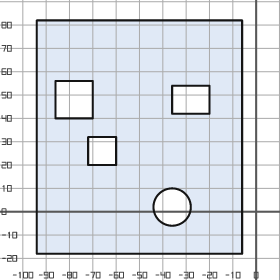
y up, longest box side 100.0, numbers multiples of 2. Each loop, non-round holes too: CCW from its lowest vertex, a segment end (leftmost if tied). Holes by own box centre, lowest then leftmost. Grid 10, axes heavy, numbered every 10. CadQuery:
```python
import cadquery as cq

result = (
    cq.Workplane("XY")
    .moveTo(-94.0, -18.0)
    .lineTo(-6.0, -18.0)
    .lineTo(-6.0, 82.0)
    .lineTo(-94.0, 82.0)
    .close()
    .moveTo(-36.0, 2.0)
    .circle(8.0)
    .moveTo(-72.0, 20.0)
    .lineTo(-60.0, 20.0)
    .lineTo(-60.0, 32.0)
    .lineTo(-72.0, 32.0)
    .close()
    .moveTo(-86.0, 40.0)
    .lineTo(-70.0, 40.0)
    .lineTo(-70.0, 56.0)
    .lineTo(-86.0, 56.0)
    .close()
    .moveTo(-36.0, 42.0)
    .lineTo(-20.0, 42.0)
    .lineTo(-20.0, 54.0)
    .lineTo(-36.0, 54.0)
    .close()
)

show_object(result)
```